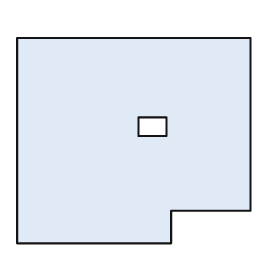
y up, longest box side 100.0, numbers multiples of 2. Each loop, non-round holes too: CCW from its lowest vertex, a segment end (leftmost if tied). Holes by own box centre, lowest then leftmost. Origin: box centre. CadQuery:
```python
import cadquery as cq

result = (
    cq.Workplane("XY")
    .moveTo(-50.0, -44.0)
    .lineTo(16.0, -44.0)
    .lineTo(16.0, -30.0)
    .lineTo(50.0, -30.0)
    .lineTo(50.0, 44.0)
    .lineTo(-50.0, 44.0)
    .close()
    .moveTo(2.0, 2.0)
    .lineTo(14.0, 2.0)
    .lineTo(14.0, 10.0)
    .lineTo(2.0, 10.0)
    .close()
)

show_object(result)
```